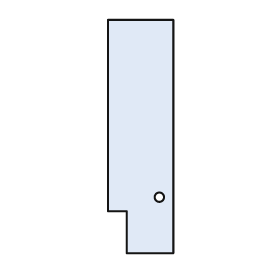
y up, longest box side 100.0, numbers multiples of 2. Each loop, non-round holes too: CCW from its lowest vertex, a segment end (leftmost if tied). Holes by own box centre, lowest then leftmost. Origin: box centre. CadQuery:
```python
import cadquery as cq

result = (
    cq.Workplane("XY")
    .moveTo(-6.0, -50.0)
    .lineTo(14.0, -50.0)
    .lineTo(14.0, 50.0)
    .lineTo(-14.0, 50.0)
    .lineTo(-14.0, -32.0)
    .lineTo(-6.0, -32.0)
    .close()
    .moveTo(8.0, -26.0)
    .circle(2.0)
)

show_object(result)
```